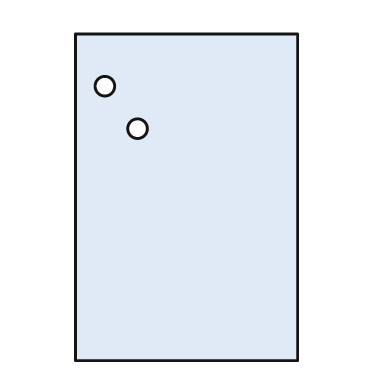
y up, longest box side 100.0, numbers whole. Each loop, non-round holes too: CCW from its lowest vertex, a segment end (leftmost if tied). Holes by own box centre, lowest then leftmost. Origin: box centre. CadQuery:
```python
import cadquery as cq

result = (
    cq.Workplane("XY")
    .moveTo(-34.0, -50.0)
    .lineTo(34.0, -50.0)
    .lineTo(34.0, 50.0)
    .lineTo(-34.0, 50.0)
    .close()
    .moveTo(-15.0, 21.0)
    .circle(3.0)
    .moveTo(-25.0, 34.0)
    .circle(3.0)
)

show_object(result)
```